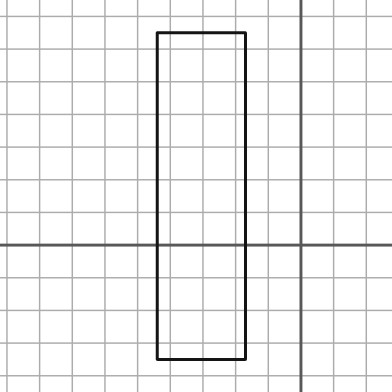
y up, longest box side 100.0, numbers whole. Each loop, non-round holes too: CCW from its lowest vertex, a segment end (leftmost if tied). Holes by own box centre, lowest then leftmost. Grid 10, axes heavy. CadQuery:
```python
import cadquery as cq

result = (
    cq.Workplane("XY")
    .moveTo(-44.0, -35.0)
    .lineTo(-17.0, -35.0)
    .lineTo(-17.0, 65.0)
    .lineTo(-44.0, 65.0)
    .close()
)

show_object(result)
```